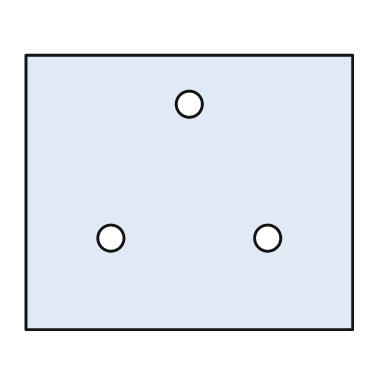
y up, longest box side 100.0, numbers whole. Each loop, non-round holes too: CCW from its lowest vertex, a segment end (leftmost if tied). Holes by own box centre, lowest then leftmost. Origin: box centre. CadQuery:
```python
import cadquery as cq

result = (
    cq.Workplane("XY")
    .moveTo(-50.0, -42.0)
    .lineTo(50.0, -42.0)
    .lineTo(50.0, 42.0)
    .lineTo(-50.0, 42.0)
    .close()
    .moveTo(-24.0, -14.0)
    .circle(4.0)
    .moveTo(24.0, -14.0)
    .circle(4.0)
    .moveTo(0.0, 27.0)
    .circle(4.0)
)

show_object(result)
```